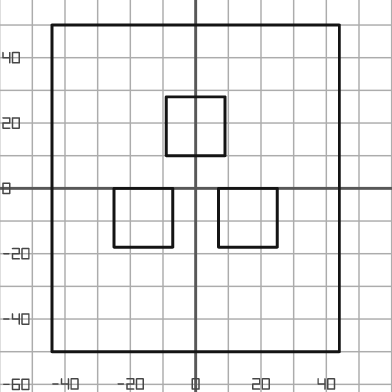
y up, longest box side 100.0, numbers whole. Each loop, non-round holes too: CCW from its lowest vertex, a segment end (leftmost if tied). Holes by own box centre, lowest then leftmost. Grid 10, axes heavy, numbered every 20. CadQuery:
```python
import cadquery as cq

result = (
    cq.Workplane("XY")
    .moveTo(-44.0, -50.0)
    .lineTo(44.0, -50.0)
    .lineTo(44.0, 50.0)
    .lineTo(-44.0, 50.0)
    .close()
    .moveTo(-25.0, -18.0)
    .lineTo(-7.0, -18.0)
    .lineTo(-7.0, 0.0)
    .lineTo(-25.0, 0.0)
    .close()
    .moveTo(7.0, -18.0)
    .lineTo(25.0, -18.0)
    .lineTo(25.0, 0.0)
    .lineTo(7.0, 0.0)
    .close()
    .moveTo(-9.0, 10.0)
    .lineTo(9.0, 10.0)
    .lineTo(9.0, 28.0)
    .lineTo(-9.0, 28.0)
    .close()
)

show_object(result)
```